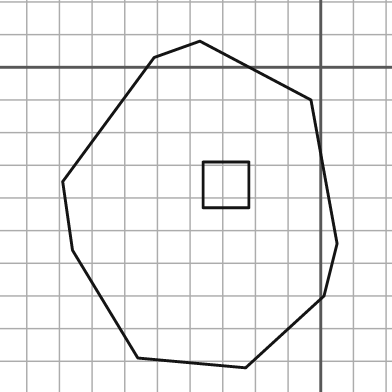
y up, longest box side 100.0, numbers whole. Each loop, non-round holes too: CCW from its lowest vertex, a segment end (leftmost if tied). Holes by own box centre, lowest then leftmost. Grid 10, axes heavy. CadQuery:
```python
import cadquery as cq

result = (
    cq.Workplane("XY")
    .moveTo(-23.0, -92.0)
    .lineTo(1.0, -70.0)
    .lineTo(5.0, -54.0)
    .lineTo(-3.0, -10.0)
    .lineTo(-37.0, 8.0)
    .lineTo(-51.0, 3.0)
    .lineTo(-79.0, -35.0)
    .lineTo(-76.0, -56.0)
    .lineTo(-56.0, -89.0)
    .close()
    .moveTo(-36.0, -43.0)
    .lineTo(-22.0, -43.0)
    .lineTo(-22.0, -29.0)
    .lineTo(-36.0, -29.0)
    .close()
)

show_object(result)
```